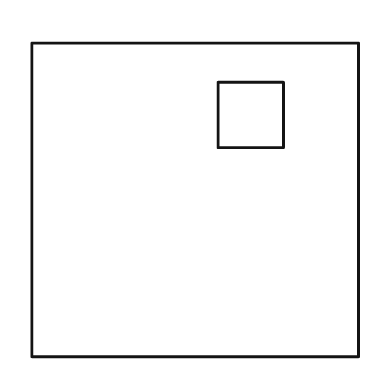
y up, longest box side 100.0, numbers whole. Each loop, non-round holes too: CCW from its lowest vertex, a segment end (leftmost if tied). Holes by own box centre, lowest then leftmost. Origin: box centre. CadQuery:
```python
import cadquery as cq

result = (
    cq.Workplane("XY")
    .moveTo(-50.0, -48.0)
    .lineTo(50.0, -48.0)
    .lineTo(50.0, 48.0)
    .lineTo(-50.0, 48.0)
    .close()
    .moveTo(7.0, 16.0)
    .lineTo(27.0, 16.0)
    .lineTo(27.0, 36.0)
    .lineTo(7.0, 36.0)
    .close()
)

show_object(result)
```